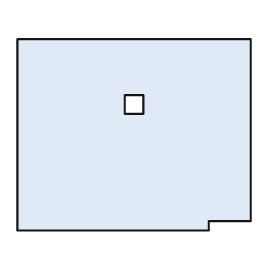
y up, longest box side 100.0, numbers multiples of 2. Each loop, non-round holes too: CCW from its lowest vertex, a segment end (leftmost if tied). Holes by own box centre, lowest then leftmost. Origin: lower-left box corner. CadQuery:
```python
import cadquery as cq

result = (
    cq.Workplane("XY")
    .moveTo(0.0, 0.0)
    .lineTo(82.0, 0.0)
    .lineTo(82.0, 4.0)
    .lineTo(100.0, 4.0)
    .lineTo(100.0, 82.0)
    .lineTo(0.0, 82.0)
    .close()
    .moveTo(46.0, 50.0)
    .lineTo(54.0, 50.0)
    .lineTo(54.0, 58.0)
    .lineTo(46.0, 58.0)
    .close()
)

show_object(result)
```